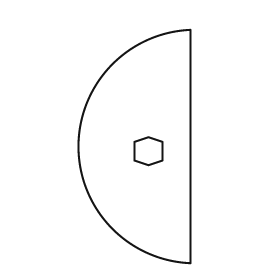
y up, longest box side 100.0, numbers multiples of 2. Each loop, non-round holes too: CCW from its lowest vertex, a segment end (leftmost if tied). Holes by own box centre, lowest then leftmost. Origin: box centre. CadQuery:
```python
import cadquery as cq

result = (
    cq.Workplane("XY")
    .moveTo(24.0, -50.0)
    .lineTo(24.0, 50.0)
    .threePointArc((-24.0, 0.0), (24.0, -50.0))
    .close()
    .moveTo(6.0, -8.0)
    .lineTo(12.0, -6.0)
    .lineTo(12.0, 2.0)
    .lineTo(6.0, 4.0)
    .lineTo(0.0, 2.0)
    .lineTo(0.0, -6.0)
    .close()
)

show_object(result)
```